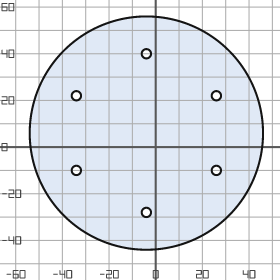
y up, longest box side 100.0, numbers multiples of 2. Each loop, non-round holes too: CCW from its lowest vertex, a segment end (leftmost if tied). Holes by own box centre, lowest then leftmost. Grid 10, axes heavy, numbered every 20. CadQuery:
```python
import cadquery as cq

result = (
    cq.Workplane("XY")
    .moveTo(-4.0, 6.0)
    .circle(50.0)
    .moveTo(-4.0, -28.0)
    .circle(2.0)
    .moveTo(-34.0, -10.0)
    .circle(2.0)
    .moveTo(26.0, -10.0)
    .circle(2.0)
    .moveTo(-34.0, 22.0)
    .circle(2.0)
    .moveTo(26.0, 22.0)
    .circle(2.0)
    .moveTo(-4.0, 40.0)
    .circle(2.0)
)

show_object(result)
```